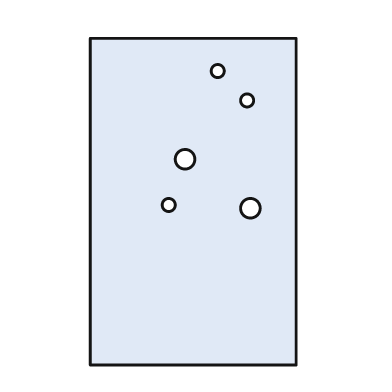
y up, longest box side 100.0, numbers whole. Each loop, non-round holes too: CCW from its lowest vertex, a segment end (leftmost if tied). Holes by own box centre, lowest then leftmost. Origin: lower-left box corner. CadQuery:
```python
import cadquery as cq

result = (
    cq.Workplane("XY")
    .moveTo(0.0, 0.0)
    .lineTo(63.0, 0.0)
    .lineTo(63.0, 100.0)
    .lineTo(0.0, 100.0)
    .close()
    .moveTo(49.0, 48.0)
    .circle(3.0)
    .moveTo(24.0, 49.0)
    .circle(2.0)
    .moveTo(29.0, 63.0)
    .circle(3.0)
    .moveTo(48.0, 81.0)
    .circle(2.0)
    .moveTo(39.0, 90.0)
    .circle(2.0)
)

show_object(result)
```